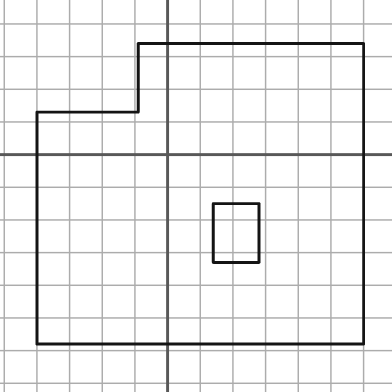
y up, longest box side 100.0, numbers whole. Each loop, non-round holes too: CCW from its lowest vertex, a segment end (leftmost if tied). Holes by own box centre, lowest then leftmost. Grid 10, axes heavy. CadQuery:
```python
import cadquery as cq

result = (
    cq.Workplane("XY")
    .moveTo(-40.0, -58.0)
    .lineTo(60.0, -58.0)
    .lineTo(60.0, 34.0)
    .lineTo(-9.0, 34.0)
    .lineTo(-9.0, 13.0)
    .lineTo(-40.0, 13.0)
    .close()
    .moveTo(14.0, -33.0)
    .lineTo(28.0, -33.0)
    .lineTo(28.0, -15.0)
    .lineTo(14.0, -15.0)
    .close()
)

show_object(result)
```